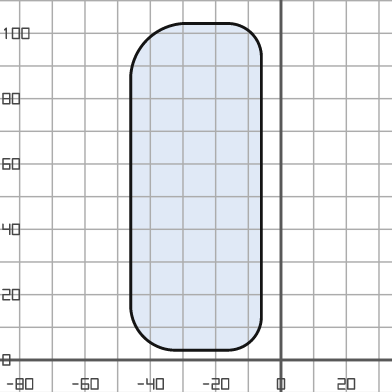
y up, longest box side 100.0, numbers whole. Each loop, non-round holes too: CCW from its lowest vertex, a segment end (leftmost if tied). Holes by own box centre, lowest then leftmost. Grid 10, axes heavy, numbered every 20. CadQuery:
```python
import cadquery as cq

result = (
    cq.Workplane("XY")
    .moveTo(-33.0, 3.0)
    .lineTo(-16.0, 3.0)
    .threePointArc((-9.0, 6.0), (-6.0, 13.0))
    .lineTo(-6.0, 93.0)
    .threePointArc((-9.0, 100.0), (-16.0, 103.0))
    .lineTo(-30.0, 103.0)
    .threePointArc((-41.0, 98.0), (-46.0, 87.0))
    .lineTo(-46.0, 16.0)
    .threePointArc((-42.0, 7.0), (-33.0, 3.0))
    .close()
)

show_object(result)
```